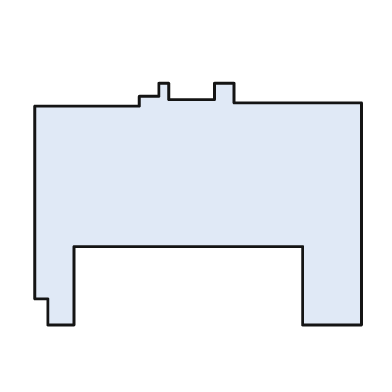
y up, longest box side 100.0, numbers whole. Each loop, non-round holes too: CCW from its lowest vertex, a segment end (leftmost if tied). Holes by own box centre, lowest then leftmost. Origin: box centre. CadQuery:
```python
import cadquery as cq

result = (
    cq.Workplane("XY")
    .moveTo(-46.0, -37.0)
    .lineTo(-38.0, -37.0)
    .lineTo(-38.0, -13.0)
    .lineTo(32.0, -13.0)
    .lineTo(32.0, -37.0)
    .lineTo(50.0, -37.0)
    .lineTo(50.0, 31.0)
    .lineTo(11.0, 31.0)
    .lineTo(11.0, 37.0)
    .lineTo(5.0, 37.0)
    .lineTo(5.0, 32.0)
    .lineTo(-9.0, 32.0)
    .lineTo(-9.0, 37.0)
    .lineTo(-12.0, 37.0)
    .lineTo(-12.0, 33.0)
    .lineTo(-18.0, 33.0)
    .lineTo(-18.0, 30.0)
    .lineTo(-50.0, 30.0)
    .lineTo(-50.0, -29.0)
    .lineTo(-46.0, -29.0)
    .close()
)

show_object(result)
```